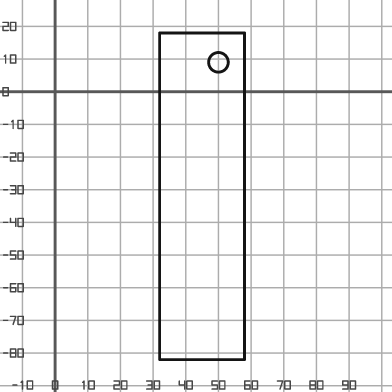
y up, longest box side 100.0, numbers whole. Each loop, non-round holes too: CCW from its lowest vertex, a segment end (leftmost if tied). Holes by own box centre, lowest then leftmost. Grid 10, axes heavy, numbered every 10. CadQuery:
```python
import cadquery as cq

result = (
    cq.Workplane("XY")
    .moveTo(32.0, -82.0)
    .lineTo(58.0, -82.0)
    .lineTo(58.0, 18.0)
    .lineTo(32.0, 18.0)
    .close()
    .moveTo(50.0, 9.0)
    .circle(3.0)
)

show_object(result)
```